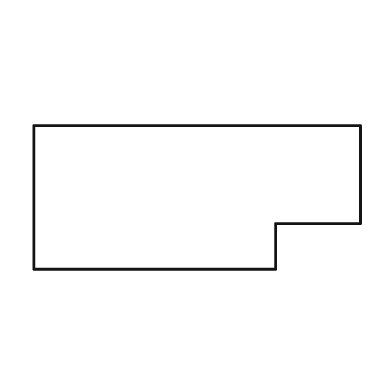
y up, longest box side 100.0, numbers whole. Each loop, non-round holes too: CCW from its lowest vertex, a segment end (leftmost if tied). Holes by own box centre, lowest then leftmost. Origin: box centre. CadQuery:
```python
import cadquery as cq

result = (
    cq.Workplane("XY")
    .moveTo(-50.0, -22.0)
    .lineTo(24.0, -22.0)
    .lineTo(24.0, -8.0)
    .lineTo(50.0, -8.0)
    .lineTo(50.0, 22.0)
    .lineTo(-50.0, 22.0)
    .close()
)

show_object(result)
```